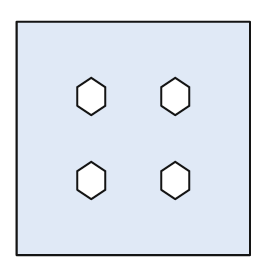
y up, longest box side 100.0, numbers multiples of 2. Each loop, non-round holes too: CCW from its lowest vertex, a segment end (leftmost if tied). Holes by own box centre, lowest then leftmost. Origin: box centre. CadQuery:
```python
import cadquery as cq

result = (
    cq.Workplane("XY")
    .moveTo(-50.0, -50.0)
    .lineTo(50.0, -50.0)
    .lineTo(50.0, 50.0)
    .lineTo(-50.0, 50.0)
    .close()
    .moveTo(-18.0, -26.0)
    .lineTo(-12.0, -22.0)
    .lineTo(-12.0, -14.0)
    .lineTo(-18.0, -10.0)
    .lineTo(-24.0, -14.0)
    .lineTo(-24.0, -22.0)
    .close()
    .moveTo(18.0, -26.0)
    .lineTo(24.0, -22.0)
    .lineTo(24.0, -14.0)
    .lineTo(18.0, -10.0)
    .lineTo(12.0, -14.0)
    .lineTo(12.0, -22.0)
    .close()
    .moveTo(-18.0, 10.0)
    .lineTo(-12.0, 14.0)
    .lineTo(-12.0, 22.0)
    .lineTo(-18.0, 26.0)
    .lineTo(-24.0, 22.0)
    .lineTo(-24.0, 14.0)
    .close()
    .moveTo(18.0, 10.0)
    .lineTo(24.0, 14.0)
    .lineTo(24.0, 22.0)
    .lineTo(18.0, 26.0)
    .lineTo(12.0, 22.0)
    .lineTo(12.0, 14.0)
    .close()
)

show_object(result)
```